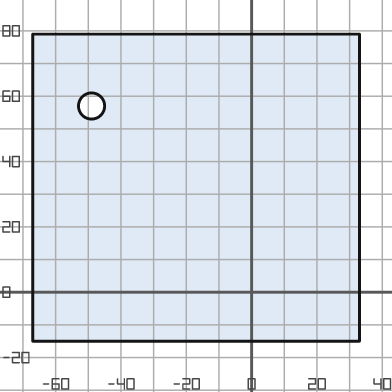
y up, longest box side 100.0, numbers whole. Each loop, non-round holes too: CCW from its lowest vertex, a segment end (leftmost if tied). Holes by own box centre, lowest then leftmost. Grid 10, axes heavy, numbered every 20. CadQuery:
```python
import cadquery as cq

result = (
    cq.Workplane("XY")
    .moveTo(-67.0, -15.0)
    .lineTo(33.0, -15.0)
    .lineTo(33.0, 79.0)
    .lineTo(-67.0, 79.0)
    .close()
    .moveTo(-49.0, 57.0)
    .circle(4.0)
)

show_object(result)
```